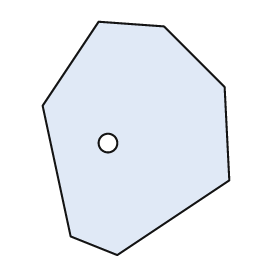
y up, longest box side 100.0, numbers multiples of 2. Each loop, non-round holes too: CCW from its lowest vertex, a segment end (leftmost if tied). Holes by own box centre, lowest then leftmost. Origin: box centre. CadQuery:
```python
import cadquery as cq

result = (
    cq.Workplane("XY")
    .moveTo(-8.0, -50.0)
    .lineTo(40.0, -18.0)
    .lineTo(38.0, 22.0)
    .lineTo(12.0, 48.0)
    .lineTo(-16.0, 50.0)
    .lineTo(-40.0, 14.0)
    .lineTo(-28.0, -42.0)
    .close()
    .moveTo(-12.0, -2.0)
    .circle(4.0)
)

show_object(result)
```